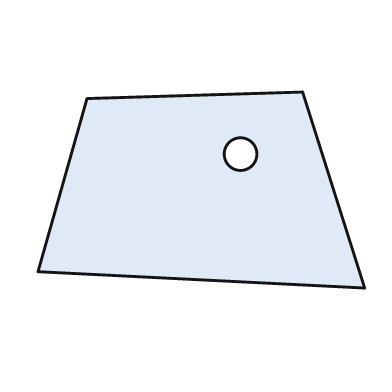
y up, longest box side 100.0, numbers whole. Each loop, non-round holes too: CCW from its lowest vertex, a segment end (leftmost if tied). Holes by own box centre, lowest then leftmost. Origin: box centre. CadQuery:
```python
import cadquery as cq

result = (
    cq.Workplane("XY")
    .moveTo(50.0, -30.0)
    .lineTo(31.0, 30.0)
    .lineTo(-35.0, 28.0)
    .lineTo(-50.0, -25.0)
    .close()
    .moveTo(12.0, 11.0)
    .circle(5.0)
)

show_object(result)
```